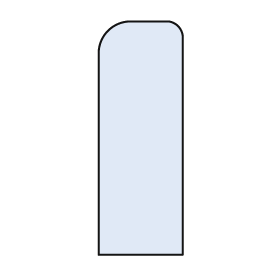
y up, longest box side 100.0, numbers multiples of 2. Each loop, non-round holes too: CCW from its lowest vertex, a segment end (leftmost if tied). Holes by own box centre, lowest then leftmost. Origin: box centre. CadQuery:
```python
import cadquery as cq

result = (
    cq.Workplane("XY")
    .moveTo(-18.0, -50.0)
    .lineTo(18.0, -50.0)
    .lineTo(18.0, 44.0)
    .threePointArc((16.0, 48.0), (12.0, 50.0))
    .lineTo(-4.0, 50.0)
    .threePointArc((-14.0, 46.0), (-18.0, 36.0))
    .close()
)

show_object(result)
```